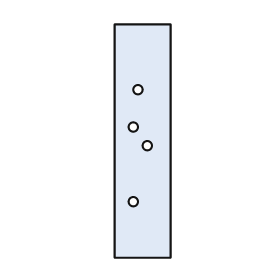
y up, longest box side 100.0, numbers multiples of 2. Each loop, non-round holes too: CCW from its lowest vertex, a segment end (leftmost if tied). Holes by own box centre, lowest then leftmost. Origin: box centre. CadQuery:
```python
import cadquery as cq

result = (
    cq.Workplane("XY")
    .moveTo(-12.0, -50.0)
    .lineTo(12.0, -50.0)
    .lineTo(12.0, 50.0)
    .lineTo(-12.0, 50.0)
    .close()
    .moveTo(-4.0, -26.0)
    .circle(2.0)
    .moveTo(2.0, -2.0)
    .circle(2.0)
    .moveTo(-4.0, 6.0)
    .circle(2.0)
    .moveTo(-2.0, 22.0)
    .circle(2.0)
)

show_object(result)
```